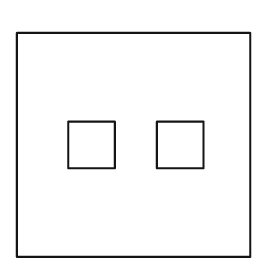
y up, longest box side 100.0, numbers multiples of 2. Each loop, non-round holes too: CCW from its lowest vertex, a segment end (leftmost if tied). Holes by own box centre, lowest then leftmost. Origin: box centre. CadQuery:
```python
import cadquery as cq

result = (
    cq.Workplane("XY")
    .moveTo(-50.0, -48.0)
    .lineTo(50.0, -48.0)
    .lineTo(50.0, 48.0)
    .lineTo(-50.0, 48.0)
    .close()
    .moveTo(-28.0, -10.0)
    .lineTo(-8.0, -10.0)
    .lineTo(-8.0, 10.0)
    .lineTo(-28.0, 10.0)
    .close()
    .moveTo(10.0, -10.0)
    .lineTo(30.0, -10.0)
    .lineTo(30.0, 10.0)
    .lineTo(10.0, 10.0)
    .close()
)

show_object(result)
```